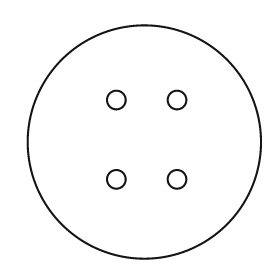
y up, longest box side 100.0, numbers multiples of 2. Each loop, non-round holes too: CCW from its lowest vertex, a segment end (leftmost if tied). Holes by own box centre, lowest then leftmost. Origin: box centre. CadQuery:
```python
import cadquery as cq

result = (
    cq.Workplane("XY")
    .moveTo(0.0, 0.0)
    .circle(50.0)
    .moveTo(-12.0, -16.0)
    .circle(4.0)
    .moveTo(14.0, -16.0)
    .circle(4.0)
    .moveTo(-12.0, 18.0)
    .circle(4.0)
    .moveTo(14.0, 18.0)
    .circle(4.0)
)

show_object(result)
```